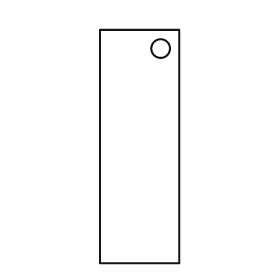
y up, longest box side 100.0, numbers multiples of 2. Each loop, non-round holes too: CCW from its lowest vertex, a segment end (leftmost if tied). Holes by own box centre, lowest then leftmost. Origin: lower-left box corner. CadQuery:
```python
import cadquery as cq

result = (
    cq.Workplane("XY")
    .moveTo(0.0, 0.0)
    .lineTo(34.0, 0.0)
    .lineTo(34.0, 100.0)
    .lineTo(0.0, 100.0)
    .close()
    .moveTo(26.0, 92.0)
    .circle(4.0)
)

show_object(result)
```